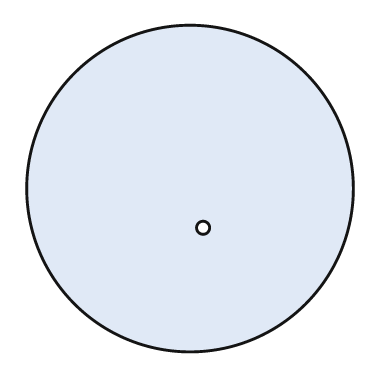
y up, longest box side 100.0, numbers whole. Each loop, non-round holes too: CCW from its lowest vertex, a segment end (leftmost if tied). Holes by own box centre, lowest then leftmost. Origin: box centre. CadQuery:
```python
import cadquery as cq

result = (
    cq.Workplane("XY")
    .moveTo(0.0, 0.0)
    .circle(50.0)
    .moveTo(4.0, -12.0)
    .circle(2.0)
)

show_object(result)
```